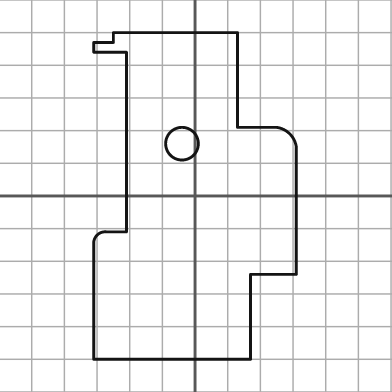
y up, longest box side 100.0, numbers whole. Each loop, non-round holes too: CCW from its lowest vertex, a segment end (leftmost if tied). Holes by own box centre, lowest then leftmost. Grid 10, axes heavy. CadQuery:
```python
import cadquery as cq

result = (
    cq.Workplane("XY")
    .moveTo(-31.0, -50.0)
    .lineTo(17.0, -50.0)
    .lineTo(17.0, -24.0)
    .lineTo(31.0, -24.0)
    .lineTo(31.0, 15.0)
    .threePointArc((29.0, 19.0), (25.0, 21.0))
    .lineTo(13.0, 21.0)
    .lineTo(13.0, 50.0)
    .lineTo(-25.0, 50.0)
    .lineTo(-25.0, 47.0)
    .lineTo(-31.0, 47.0)
    .lineTo(-31.0, 44.0)
    .lineTo(-21.0, 44.0)
    .lineTo(-21.0, -11.0)
    .lineTo(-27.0, -11.0)
    .threePointArc((-30.0, -12.0), (-31.0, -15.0))
    .close()
    .moveTo(-4.0, 16.0)
    .circle(5.0)
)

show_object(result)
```